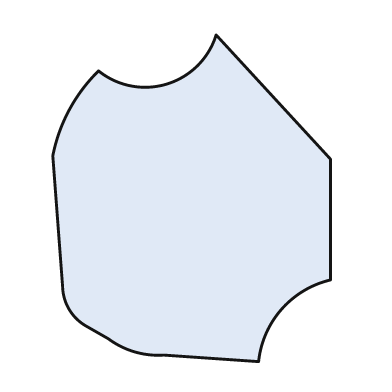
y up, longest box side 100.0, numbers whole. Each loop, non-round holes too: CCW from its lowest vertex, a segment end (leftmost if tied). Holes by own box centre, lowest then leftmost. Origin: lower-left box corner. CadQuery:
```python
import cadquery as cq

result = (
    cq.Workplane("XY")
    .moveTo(63.0, 0.0)
    .threePointArc((70.0, 16.0), (85.0, 25.0))
    .lineTo(85.0, 62.0)
    .lineTo(50.0, 100.0)
    .threePointArc((35.0, 85.0), (14.0, 89.0))
    .threePointArc((5.0, 77.0), (0.0, 63.0))
    .lineTo(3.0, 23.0)
    .threePointArc((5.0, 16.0), (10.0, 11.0))
    .lineTo(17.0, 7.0)
    .threePointArc((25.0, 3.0), (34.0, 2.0))
    .close()
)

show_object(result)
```